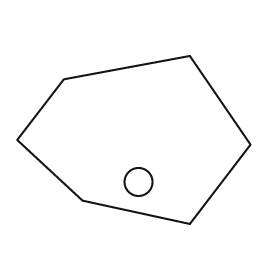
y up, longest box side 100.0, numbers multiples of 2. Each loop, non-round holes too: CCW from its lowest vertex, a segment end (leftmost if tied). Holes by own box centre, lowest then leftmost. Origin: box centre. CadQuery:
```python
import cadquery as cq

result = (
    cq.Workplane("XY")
    .moveTo(24.0, -36.0)
    .lineTo(50.0, -2.0)
    .lineTo(24.0, 36.0)
    .lineTo(-30.0, 26.0)
    .lineTo(-50.0, 0.0)
    .lineTo(-22.0, -26.0)
    .close()
    .moveTo(2.0, -18.0)
    .circle(6.0)
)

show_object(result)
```